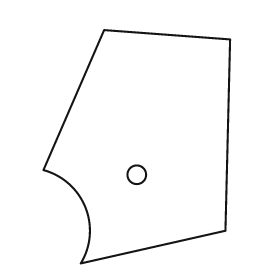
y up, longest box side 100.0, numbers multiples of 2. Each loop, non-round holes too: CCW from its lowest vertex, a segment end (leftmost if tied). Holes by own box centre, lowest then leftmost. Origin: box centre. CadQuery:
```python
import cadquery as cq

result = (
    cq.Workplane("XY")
    .moveTo(-24.0, -50.0)
    .lineTo(38.0, -36.0)
    .lineTo(40.0, 46.0)
    .lineTo(-14.0, 50.0)
    .lineTo(-40.0, -10.0)
    .threePointArc((-22.0, -26.0), (-24.0, -50.0))
    .close()
    .moveTo(0.0, -12.0)
    .circle(4.0)
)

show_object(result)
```